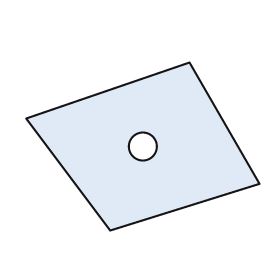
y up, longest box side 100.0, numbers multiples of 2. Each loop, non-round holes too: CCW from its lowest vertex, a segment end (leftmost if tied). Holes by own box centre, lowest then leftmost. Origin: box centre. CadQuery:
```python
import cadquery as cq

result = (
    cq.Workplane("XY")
    .moveTo(-14.0, -36.0)
    .lineTo(50.0, -16.0)
    .lineTo(20.0, 36.0)
    .lineTo(-50.0, 12.0)
    .close()
    .moveTo(0.0, 0.0)
    .circle(6.0)
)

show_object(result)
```